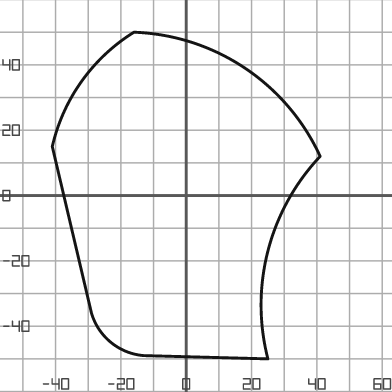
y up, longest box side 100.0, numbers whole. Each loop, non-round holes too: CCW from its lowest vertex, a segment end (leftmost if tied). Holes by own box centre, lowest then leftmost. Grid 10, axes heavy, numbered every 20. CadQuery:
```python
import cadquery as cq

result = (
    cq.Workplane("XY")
    .moveTo(25.0, -50.0)
    .threePointArc((25.0, -17.0), (41.0, 12.0))
    .threePointArc((18.0, 39.0), (-16.0, 50.0))
    .threePointArc((-32.0, 35.0), (-41.0, 15.0))
    .lineTo(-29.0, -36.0)
    .threePointArc((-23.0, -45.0), (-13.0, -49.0))
    .close()
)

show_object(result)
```